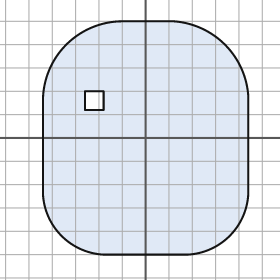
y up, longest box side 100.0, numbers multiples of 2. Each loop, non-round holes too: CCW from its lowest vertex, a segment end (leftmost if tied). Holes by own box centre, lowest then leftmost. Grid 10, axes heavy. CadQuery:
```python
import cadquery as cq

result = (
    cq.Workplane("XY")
    .moveTo(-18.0, -50.0)
    .lineTo(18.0, -50.0)
    .threePointArc((36.0, -42.0), (44.0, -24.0))
    .lineTo(44.0, 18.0)
    .threePointArc((34.0, 40.0), (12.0, 50.0))
    .lineTo(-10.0, 50.0)
    .threePointArc((-34.0, 40.0), (-44.0, 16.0))
    .lineTo(-44.0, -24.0)
    .threePointArc((-36.0, -42.0), (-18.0, -50.0))
    .close()
    .moveTo(-26.0, 12.0)
    .lineTo(-18.0, 12.0)
    .lineTo(-18.0, 20.0)
    .lineTo(-26.0, 20.0)
    .close()
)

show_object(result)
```